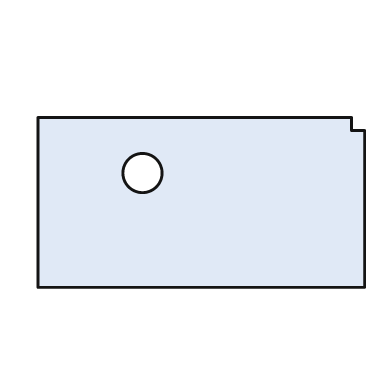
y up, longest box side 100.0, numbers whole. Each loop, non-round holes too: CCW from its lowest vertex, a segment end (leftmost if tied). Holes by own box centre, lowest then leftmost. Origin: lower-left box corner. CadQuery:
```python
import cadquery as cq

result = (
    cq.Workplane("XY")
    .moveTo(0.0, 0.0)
    .lineTo(100.0, 0.0)
    .lineTo(100.0, 48.0)
    .lineTo(96.0, 48.0)
    .lineTo(96.0, 52.0)
    .lineTo(0.0, 52.0)
    .close()
    .moveTo(32.0, 35.0)
    .circle(6.0)
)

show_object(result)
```